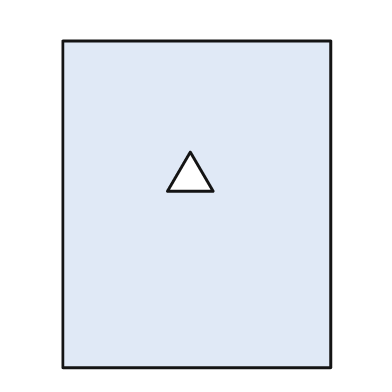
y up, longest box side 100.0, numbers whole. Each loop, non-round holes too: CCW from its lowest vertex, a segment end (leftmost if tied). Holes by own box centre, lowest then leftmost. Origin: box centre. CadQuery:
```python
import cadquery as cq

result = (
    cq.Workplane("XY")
    .moveTo(-41.0, -50.0)
    .lineTo(41.0, -50.0)
    .lineTo(41.0, 50.0)
    .lineTo(-41.0, 50.0)
    .close()
    .moveTo(-9.0, 4.0)
    .lineTo(5.0, 4.0)
    .lineTo(-2.0, 16.0)
    .close()
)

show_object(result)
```